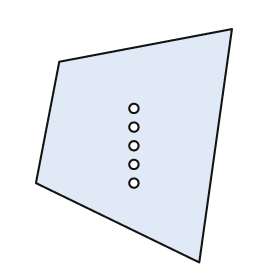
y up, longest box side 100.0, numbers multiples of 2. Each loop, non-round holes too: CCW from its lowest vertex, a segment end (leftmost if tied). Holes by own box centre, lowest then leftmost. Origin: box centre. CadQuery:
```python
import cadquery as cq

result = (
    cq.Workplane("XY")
    .moveTo(28.0, -50.0)
    .lineTo(42.0, 50.0)
    .lineTo(-32.0, 36.0)
    .lineTo(-42.0, -16.0)
    .close()
    .moveTo(0.0, -16.0)
    .circle(2.0)
    .moveTo(0.0, -8.0)
    .circle(2.0)
    .moveTo(0.0, 0.0)
    .circle(2.0)
    .moveTo(0.0, 8.0)
    .circle(2.0)
    .moveTo(0.0, 16.0)
    .circle(2.0)
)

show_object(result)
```